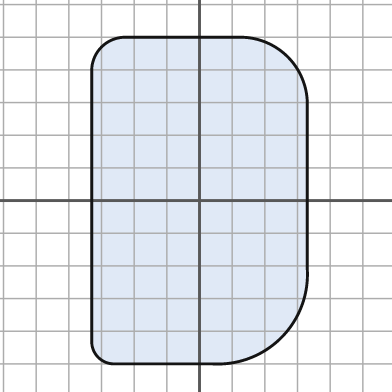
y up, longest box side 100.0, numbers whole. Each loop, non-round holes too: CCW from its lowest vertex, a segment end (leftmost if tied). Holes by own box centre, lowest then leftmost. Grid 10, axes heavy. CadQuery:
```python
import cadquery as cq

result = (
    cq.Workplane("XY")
    .moveTo(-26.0, -50.0)
    .lineTo(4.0, -50.0)
    .threePointArc((25.0, -42.0), (33.0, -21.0))
    .lineTo(33.0, 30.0)
    .threePointArc((27.0, 44.0), (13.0, 50.0))
    .lineTo(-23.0, 50.0)
    .threePointArc((-30.0, 47.0), (-33.0, 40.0))
    .lineTo(-33.0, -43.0)
    .threePointArc((-31.0, -48.0), (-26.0, -50.0))
    .close()
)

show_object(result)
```